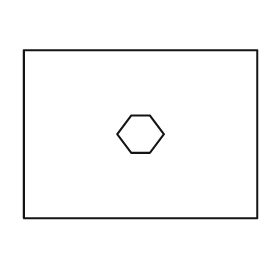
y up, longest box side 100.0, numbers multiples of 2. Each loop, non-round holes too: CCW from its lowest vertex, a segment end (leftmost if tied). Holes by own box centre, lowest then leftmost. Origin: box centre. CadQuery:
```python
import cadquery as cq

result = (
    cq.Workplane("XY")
    .moveTo(-50.0, -36.0)
    .lineTo(50.0, -36.0)
    .lineTo(50.0, 36.0)
    .lineTo(-50.0, 36.0)
    .close()
    .moveTo(-4.0, -8.0)
    .lineTo(4.0, -8.0)
    .lineTo(10.0, 0.0)
    .lineTo(4.0, 8.0)
    .lineTo(-4.0, 8.0)
    .lineTo(-10.0, 0.0)
    .close()
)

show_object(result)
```